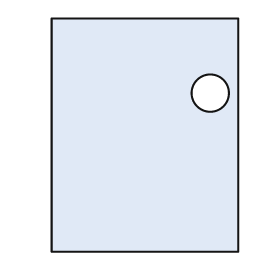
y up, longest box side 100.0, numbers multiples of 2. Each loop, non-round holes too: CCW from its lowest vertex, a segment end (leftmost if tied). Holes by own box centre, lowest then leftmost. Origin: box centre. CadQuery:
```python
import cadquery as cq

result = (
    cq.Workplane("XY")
    .moveTo(-40.0, -50.0)
    .lineTo(40.0, -50.0)
    .lineTo(40.0, 50.0)
    .lineTo(-40.0, 50.0)
    .close()
    .moveTo(28.0, 18.0)
    .circle(8.0)
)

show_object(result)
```